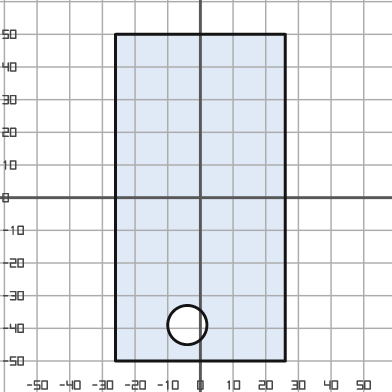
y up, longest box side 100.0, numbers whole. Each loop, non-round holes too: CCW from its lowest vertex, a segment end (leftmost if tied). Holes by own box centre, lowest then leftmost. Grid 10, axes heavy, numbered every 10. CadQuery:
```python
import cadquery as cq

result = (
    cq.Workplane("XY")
    .moveTo(-26.0, -50.0)
    .lineTo(26.0, -50.0)
    .lineTo(26.0, 50.0)
    .lineTo(-26.0, 50.0)
    .close()
    .moveTo(-4.0, -39.0)
    .circle(6.0)
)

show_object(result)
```